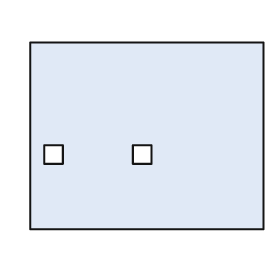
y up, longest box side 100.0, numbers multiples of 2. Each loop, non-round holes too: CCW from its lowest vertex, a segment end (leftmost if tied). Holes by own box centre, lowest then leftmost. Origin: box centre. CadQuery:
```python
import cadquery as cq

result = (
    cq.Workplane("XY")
    .moveTo(-50.0, -40.0)
    .lineTo(50.0, -40.0)
    .lineTo(50.0, 40.0)
    .lineTo(-50.0, 40.0)
    .close()
    .moveTo(-44.0, -12.0)
    .lineTo(-36.0, -12.0)
    .lineTo(-36.0, -4.0)
    .lineTo(-44.0, -4.0)
    .close()
    .moveTo(-6.0, -12.0)
    .lineTo(2.0, -12.0)
    .lineTo(2.0, -4.0)
    .lineTo(-6.0, -4.0)
    .close()
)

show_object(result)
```